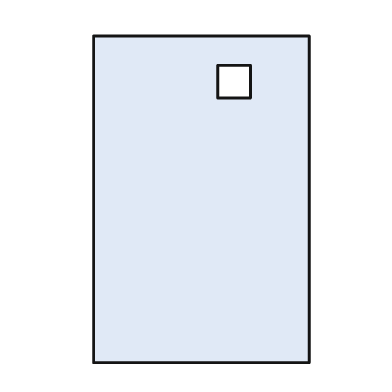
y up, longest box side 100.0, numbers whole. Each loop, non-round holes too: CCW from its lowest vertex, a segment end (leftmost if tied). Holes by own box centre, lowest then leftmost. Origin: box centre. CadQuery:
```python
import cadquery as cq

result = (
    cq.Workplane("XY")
    .moveTo(-33.0, -50.0)
    .lineTo(33.0, -50.0)
    .lineTo(33.0, 50.0)
    .lineTo(-33.0, 50.0)
    .close()
    .moveTo(5.0, 31.0)
    .lineTo(15.0, 31.0)
    .lineTo(15.0, 41.0)
    .lineTo(5.0, 41.0)
    .close()
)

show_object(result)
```